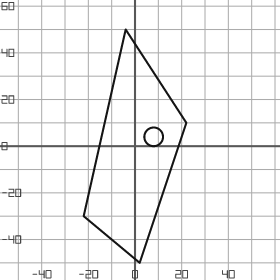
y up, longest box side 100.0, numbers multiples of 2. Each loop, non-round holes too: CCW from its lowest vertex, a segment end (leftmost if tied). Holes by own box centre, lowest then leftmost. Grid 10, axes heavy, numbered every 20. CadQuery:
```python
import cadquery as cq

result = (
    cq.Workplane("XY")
    .moveTo(2.0, -50.0)
    .lineTo(22.0, 10.0)
    .lineTo(-4.0, 50.0)
    .lineTo(-22.0, -30.0)
    .close()
    .moveTo(8.0, 4.0)
    .circle(4.0)
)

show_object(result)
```